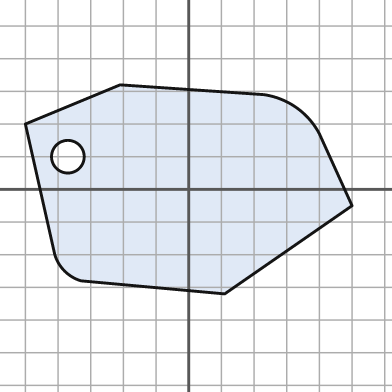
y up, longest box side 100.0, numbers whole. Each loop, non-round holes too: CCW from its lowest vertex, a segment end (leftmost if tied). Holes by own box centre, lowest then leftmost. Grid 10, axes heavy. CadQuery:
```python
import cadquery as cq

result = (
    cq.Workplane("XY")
    .moveTo(11.0, -32.0)
    .lineTo(50.0, -5.0)
    .lineTo(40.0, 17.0)
    .threePointArc((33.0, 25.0), (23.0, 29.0))
    .lineTo(-21.0, 32.0)
    .lineTo(-50.0, 20.0)
    .lineTo(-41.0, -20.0)
    .threePointArc((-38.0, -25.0), (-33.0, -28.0))
    .close()
    .moveTo(-37.0, 10.0)
    .circle(5.0)
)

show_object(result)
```